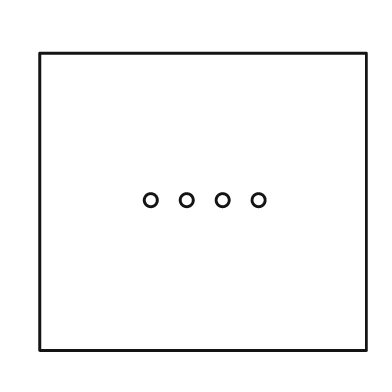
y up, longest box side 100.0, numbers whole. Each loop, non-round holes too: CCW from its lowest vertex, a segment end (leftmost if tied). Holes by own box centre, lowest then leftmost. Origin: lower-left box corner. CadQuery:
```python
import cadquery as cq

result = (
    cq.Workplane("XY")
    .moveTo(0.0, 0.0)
    .lineTo(100.0, 0.0)
    .lineTo(100.0, 91.0)
    .lineTo(0.0, 91.0)
    .close()
    .moveTo(34.0, 46.0)
    .circle(2.0)
    .moveTo(45.0, 46.0)
    .circle(2.0)
    .moveTo(56.0, 46.0)
    .circle(2.0)
    .moveTo(67.0, 46.0)
    .circle(2.0)
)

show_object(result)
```